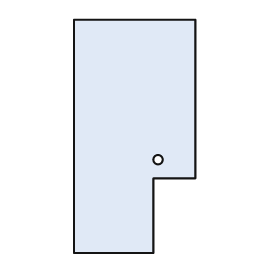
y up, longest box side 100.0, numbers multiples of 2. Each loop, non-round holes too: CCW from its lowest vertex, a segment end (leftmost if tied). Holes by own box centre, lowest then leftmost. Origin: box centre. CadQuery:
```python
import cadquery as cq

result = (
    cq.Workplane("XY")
    .moveTo(-26.0, -50.0)
    .lineTo(8.0, -50.0)
    .lineTo(8.0, -18.0)
    .lineTo(26.0, -18.0)
    .lineTo(26.0, 50.0)
    .lineTo(-26.0, 50.0)
    .close()
    .moveTo(10.0, -10.0)
    .circle(2.0)
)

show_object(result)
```